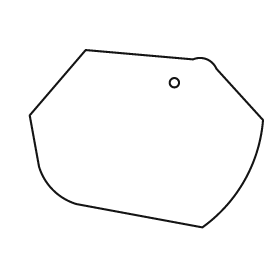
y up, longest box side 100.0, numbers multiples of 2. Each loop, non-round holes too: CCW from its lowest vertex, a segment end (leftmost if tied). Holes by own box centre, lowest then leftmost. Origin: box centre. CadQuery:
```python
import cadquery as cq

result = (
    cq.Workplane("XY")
    .moveTo(24.0, -38.0)
    .threePointArc((42.0, -18.0), (50.0, 8.0))
    .lineTo(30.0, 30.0)
    .threePointArc((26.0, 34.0), (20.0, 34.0))
    .lineTo(-26.0, 38.0)
    .lineTo(-50.0, 10.0)
    .lineTo(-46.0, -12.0)
    .threePointArc((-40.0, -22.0), (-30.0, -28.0))
    .close()
    .moveTo(12.0, 24.0)
    .circle(2.0)
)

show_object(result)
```